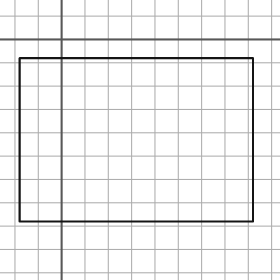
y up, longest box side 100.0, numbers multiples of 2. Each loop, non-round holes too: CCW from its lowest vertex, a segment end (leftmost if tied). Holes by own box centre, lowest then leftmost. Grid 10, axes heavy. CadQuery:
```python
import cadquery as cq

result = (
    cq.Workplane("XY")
    .moveTo(-18.0, -78.0)
    .lineTo(82.0, -78.0)
    .lineTo(82.0, -8.0)
    .lineTo(-18.0, -8.0)
    .close()
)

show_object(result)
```